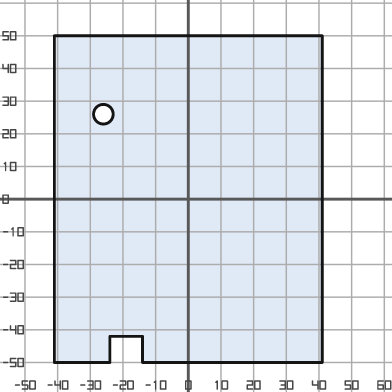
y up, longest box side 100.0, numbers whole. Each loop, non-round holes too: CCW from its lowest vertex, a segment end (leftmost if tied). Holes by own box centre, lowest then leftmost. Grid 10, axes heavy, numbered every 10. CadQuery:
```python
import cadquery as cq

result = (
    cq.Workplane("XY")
    .moveTo(-41.0, -50.0)
    .lineTo(-24.0, -50.0)
    .lineTo(-24.0, -42.0)
    .lineTo(-14.0, -42.0)
    .lineTo(-14.0, -50.0)
    .lineTo(41.0, -50.0)
    .lineTo(41.0, 50.0)
    .lineTo(-41.0, 50.0)
    .close()
    .moveTo(-26.0, 26.0)
    .circle(3.0)
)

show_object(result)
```